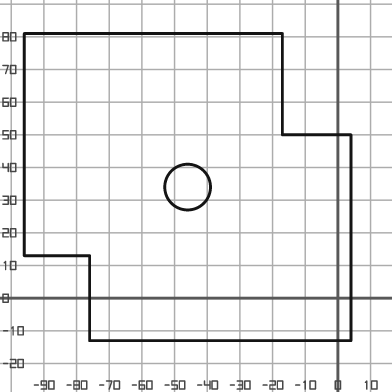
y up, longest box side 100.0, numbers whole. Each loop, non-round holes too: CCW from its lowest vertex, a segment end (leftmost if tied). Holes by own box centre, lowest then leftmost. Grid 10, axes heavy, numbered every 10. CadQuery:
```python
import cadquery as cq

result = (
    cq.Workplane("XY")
    .moveTo(-76.0, -13.0)
    .lineTo(4.0, -13.0)
    .lineTo(4.0, 50.0)
    .lineTo(-17.0, 50.0)
    .lineTo(-17.0, 81.0)
    .lineTo(-96.0, 81.0)
    .lineTo(-96.0, 13.0)
    .lineTo(-76.0, 13.0)
    .close()
    .moveTo(-46.0, 34.0)
    .circle(7.0)
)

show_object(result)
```